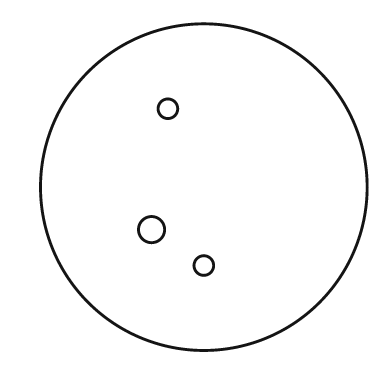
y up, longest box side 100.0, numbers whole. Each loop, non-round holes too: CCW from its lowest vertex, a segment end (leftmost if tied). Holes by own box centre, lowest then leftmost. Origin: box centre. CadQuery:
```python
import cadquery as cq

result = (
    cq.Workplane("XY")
    .moveTo(0.0, 0.0)
    .circle(50.0)
    .moveTo(0.0, -24.0)
    .circle(3.0)
    .moveTo(-16.0, -13.0)
    .circle(4.0)
    .moveTo(-11.0, 24.0)
    .circle(3.0)
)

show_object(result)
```